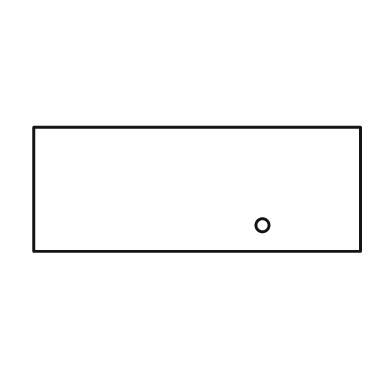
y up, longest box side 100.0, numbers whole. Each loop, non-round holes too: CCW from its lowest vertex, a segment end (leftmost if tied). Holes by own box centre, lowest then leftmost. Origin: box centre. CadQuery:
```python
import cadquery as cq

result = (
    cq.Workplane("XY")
    .moveTo(-50.0, -19.0)
    .lineTo(50.0, -19.0)
    .lineTo(50.0, 19.0)
    .lineTo(-50.0, 19.0)
    .close()
    .moveTo(20.0, -11.0)
    .circle(2.0)
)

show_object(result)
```